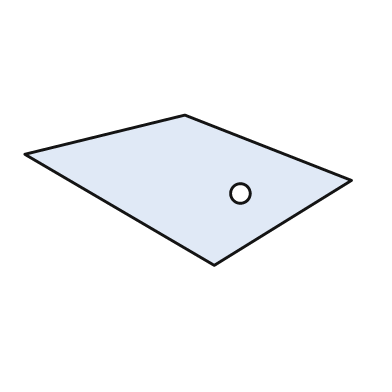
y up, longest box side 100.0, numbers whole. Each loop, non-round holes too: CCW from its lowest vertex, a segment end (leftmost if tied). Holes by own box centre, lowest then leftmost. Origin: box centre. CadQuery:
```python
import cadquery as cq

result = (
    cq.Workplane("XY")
    .moveTo(8.0, -23.0)
    .lineTo(50.0, 3.0)
    .lineTo(-1.0, 23.0)
    .lineTo(-50.0, 11.0)
    .close()
    .moveTo(16.0, -1.0)
    .circle(3.0)
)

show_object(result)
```